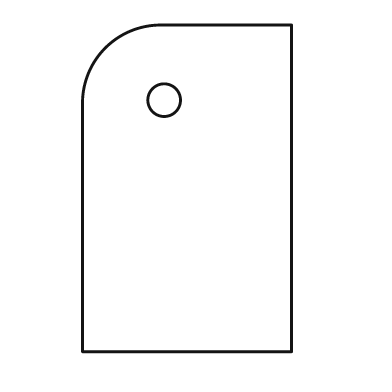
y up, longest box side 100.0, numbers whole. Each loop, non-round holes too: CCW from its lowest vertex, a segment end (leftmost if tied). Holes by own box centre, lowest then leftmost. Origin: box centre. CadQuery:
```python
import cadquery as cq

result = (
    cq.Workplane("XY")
    .moveTo(-32.0, -50.0)
    .lineTo(32.0, -50.0)
    .lineTo(32.0, 50.0)
    .lineTo(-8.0, 50.0)
    .threePointArc((-25.0, 43.0), (-32.0, 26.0))
    .close()
    .moveTo(-7.0, 27.0)
    .circle(5.0)
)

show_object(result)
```